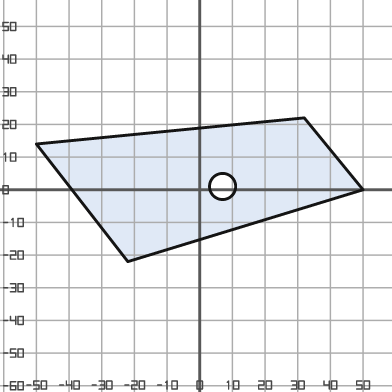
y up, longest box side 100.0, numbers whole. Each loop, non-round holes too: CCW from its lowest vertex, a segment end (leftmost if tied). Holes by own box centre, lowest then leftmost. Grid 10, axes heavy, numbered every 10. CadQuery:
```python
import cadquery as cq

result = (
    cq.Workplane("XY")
    .moveTo(-22.0, -22.0)
    .lineTo(50.0, 0.0)
    .lineTo(32.0, 22.0)
    .lineTo(-50.0, 14.0)
    .close()
    .moveTo(7.0, 1.0)
    .circle(4.0)
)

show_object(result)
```